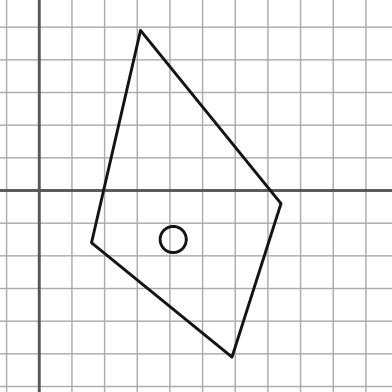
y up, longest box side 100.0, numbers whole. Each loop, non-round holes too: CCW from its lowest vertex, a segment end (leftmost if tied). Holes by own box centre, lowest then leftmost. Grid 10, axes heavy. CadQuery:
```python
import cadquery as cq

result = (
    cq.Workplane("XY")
    .moveTo(59.0, -51.0)
    .lineTo(74.0, -4.0)
    .lineTo(31.0, 49.0)
    .lineTo(16.0, -16.0)
    .close()
    .moveTo(41.0, -15.0)
    .circle(4.0)
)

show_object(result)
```